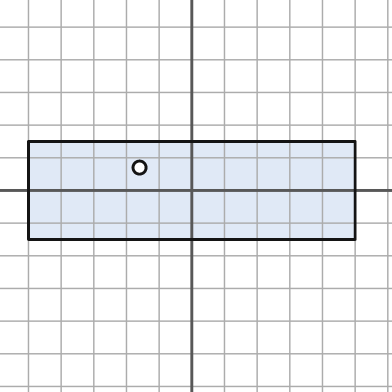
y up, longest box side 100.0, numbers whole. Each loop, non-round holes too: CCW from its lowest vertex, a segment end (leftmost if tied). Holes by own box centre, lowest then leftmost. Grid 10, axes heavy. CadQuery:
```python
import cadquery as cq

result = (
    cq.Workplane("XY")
    .moveTo(-50.0, -15.0)
    .lineTo(50.0, -15.0)
    .lineTo(50.0, 15.0)
    .lineTo(-50.0, 15.0)
    .close()
    .moveTo(-16.0, 7.0)
    .circle(2.0)
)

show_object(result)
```